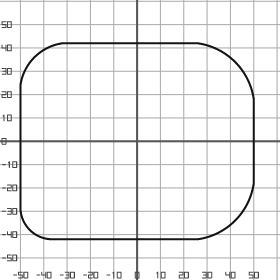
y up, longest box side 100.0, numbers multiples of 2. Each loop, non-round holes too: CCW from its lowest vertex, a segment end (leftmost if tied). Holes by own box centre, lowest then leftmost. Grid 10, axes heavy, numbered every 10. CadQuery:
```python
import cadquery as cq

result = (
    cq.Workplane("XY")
    .moveTo(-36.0, -42.0)
    .lineTo(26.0, -42.0)
    .threePointArc((42.0, -34.0), (50.0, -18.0))
    .lineTo(50.0, 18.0)
    .threePointArc((42.0, 34.0), (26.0, 42.0))
    .lineTo(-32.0, 42.0)
    .threePointArc((-44.0, 36.0), (-50.0, 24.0))
    .lineTo(-50.0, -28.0)
    .threePointArc((-46.0, -38.0), (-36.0, -42.0))
    .close()
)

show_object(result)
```